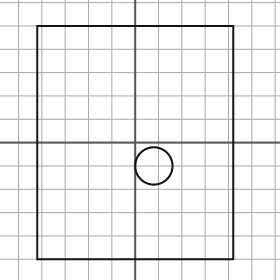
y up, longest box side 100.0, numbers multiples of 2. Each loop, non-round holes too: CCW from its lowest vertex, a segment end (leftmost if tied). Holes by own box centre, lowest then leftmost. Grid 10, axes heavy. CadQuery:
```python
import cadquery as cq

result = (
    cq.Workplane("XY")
    .moveTo(-42.0, -50.0)
    .lineTo(42.0, -50.0)
    .lineTo(42.0, 50.0)
    .lineTo(-42.0, 50.0)
    .close()
    .moveTo(8.0, -10.0)
    .circle(8.0)
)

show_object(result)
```